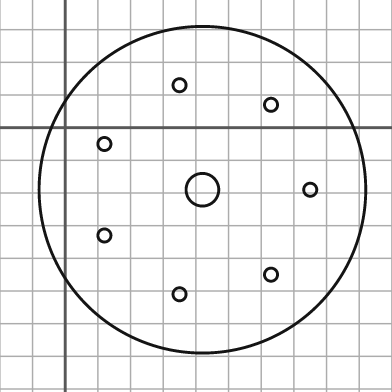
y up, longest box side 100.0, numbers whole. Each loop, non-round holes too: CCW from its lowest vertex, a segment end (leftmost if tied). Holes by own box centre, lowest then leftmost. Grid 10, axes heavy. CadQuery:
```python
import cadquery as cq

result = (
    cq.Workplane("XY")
    .moveTo(42.0, -19.0)
    .circle(50.0)
    .moveTo(35.0, -51.0)
    .circle(2.0)
    .moveTo(63.0, -45.0)
    .circle(2.0)
    .moveTo(12.0, -33.0)
    .circle(2.0)
    .moveTo(42.0, -19.0)
    .circle(5.0)
    .moveTo(75.0, -19.0)
    .circle(2.0)
    .moveTo(12.0, -5.0)
    .circle(2.0)
    .moveTo(63.0, 7.0)
    .circle(2.0)
    .moveTo(35.0, 13.0)
    .circle(2.0)
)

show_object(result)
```